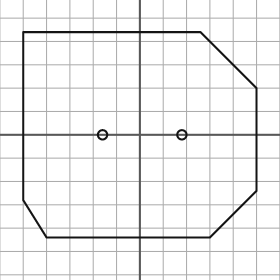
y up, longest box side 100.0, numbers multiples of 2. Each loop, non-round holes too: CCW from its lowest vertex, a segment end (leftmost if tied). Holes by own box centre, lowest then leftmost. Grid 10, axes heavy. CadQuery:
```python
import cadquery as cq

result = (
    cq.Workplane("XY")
    .moveTo(-40.0, -44.0)
    .lineTo(30.0, -44.0)
    .lineTo(50.0, -24.0)
    .lineTo(50.0, 20.0)
    .lineTo(26.0, 44.0)
    .lineTo(-50.0, 44.0)
    .lineTo(-50.0, -28.0)
    .close()
    .moveTo(-16.0, 0.0)
    .circle(2.0)
    .moveTo(18.0, 0.0)
    .circle(2.0)
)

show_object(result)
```